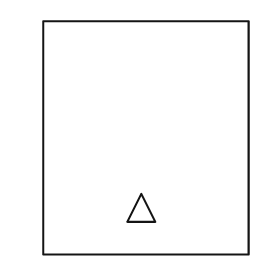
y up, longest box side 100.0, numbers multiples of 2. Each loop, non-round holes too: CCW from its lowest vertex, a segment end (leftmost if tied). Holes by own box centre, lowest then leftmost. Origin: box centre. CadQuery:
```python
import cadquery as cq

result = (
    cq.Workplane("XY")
    .moveTo(-44.0, -50.0)
    .lineTo(44.0, -50.0)
    .lineTo(44.0, 50.0)
    .lineTo(-44.0, 50.0)
    .close()
    .moveTo(-8.0, -36.0)
    .lineTo(4.0, -36.0)
    .lineTo(-2.0, -24.0)
    .close()
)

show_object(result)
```